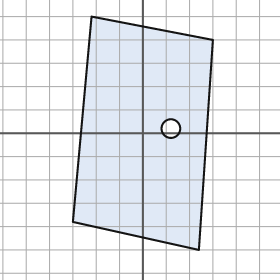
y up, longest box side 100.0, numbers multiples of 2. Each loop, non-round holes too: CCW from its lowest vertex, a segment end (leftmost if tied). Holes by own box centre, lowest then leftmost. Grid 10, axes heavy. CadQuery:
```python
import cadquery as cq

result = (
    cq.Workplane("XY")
    .moveTo(24.0, -50.0)
    .lineTo(30.0, 40.0)
    .lineTo(-22.0, 50.0)
    .lineTo(-30.0, -38.0)
    .close()
    .moveTo(12.0, 2.0)
    .circle(4.0)
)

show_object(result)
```